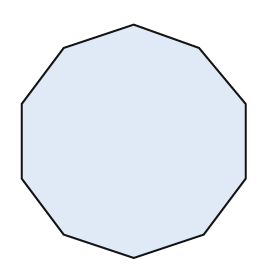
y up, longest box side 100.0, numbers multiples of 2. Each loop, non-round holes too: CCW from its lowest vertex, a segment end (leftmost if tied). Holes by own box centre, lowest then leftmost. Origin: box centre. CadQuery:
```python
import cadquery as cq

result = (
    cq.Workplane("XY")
    .moveTo(0.0, -50.0)
    .lineTo(30.0, -40.0)
    .lineTo(48.0, -16.0)
    .lineTo(48.0, 16.0)
    .lineTo(28.0, 40.0)
    .lineTo(0.0, 50.0)
    .lineTo(-30.0, 40.0)
    .lineTo(-48.0, 16.0)
    .lineTo(-48.0, -16.0)
    .lineTo(-30.0, -40.0)
    .close()
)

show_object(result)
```